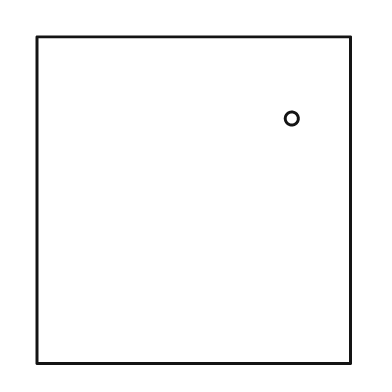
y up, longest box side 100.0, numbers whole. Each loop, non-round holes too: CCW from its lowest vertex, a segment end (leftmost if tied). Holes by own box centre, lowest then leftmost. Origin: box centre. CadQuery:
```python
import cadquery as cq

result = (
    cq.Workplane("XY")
    .moveTo(-48.0, -50.0)
    .lineTo(48.0, -50.0)
    .lineTo(48.0, 50.0)
    .lineTo(-48.0, 50.0)
    .close()
    .moveTo(30.0, 25.0)
    .circle(2.0)
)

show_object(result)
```